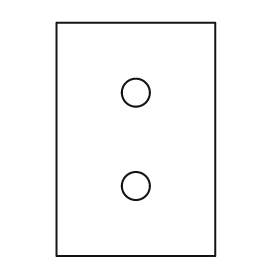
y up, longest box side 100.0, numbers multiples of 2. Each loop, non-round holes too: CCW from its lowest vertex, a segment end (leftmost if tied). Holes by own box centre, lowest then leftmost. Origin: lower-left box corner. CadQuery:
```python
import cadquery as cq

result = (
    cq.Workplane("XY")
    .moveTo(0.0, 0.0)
    .lineTo(68.0, 0.0)
    .lineTo(68.0, 100.0)
    .lineTo(0.0, 100.0)
    .close()
    .moveTo(34.0, 30.0)
    .circle(6.0)
    .moveTo(34.0, 70.0)
    .circle(6.0)
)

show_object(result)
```